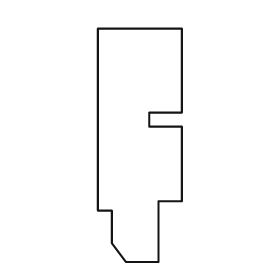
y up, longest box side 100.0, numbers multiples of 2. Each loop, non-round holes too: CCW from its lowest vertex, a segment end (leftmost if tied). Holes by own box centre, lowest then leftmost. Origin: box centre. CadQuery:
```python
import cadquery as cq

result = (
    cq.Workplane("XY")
    .moveTo(-6.0, -50.0)
    .lineTo(8.0, -50.0)
    .lineTo(8.0, -24.0)
    .lineTo(18.0, -24.0)
    .lineTo(18.0, 8.0)
    .lineTo(4.0, 8.0)
    .lineTo(4.0, 14.0)
    .lineTo(18.0, 14.0)
    .lineTo(18.0, 50.0)
    .lineTo(-18.0, 50.0)
    .lineTo(-18.0, -28.0)
    .lineTo(-12.0, -28.0)
    .lineTo(-12.0, -42.0)
    .close()
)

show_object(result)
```